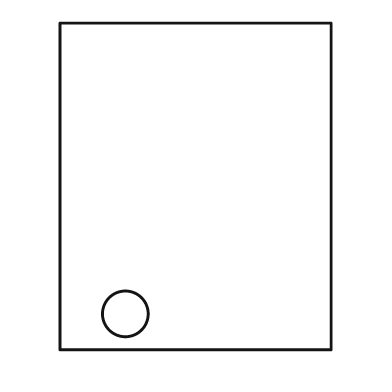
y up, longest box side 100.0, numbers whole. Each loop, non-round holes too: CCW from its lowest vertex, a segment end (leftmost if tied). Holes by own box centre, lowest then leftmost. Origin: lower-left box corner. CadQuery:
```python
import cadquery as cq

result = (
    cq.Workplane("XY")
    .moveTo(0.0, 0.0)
    .lineTo(83.0, 0.0)
    .lineTo(83.0, 100.0)
    .lineTo(0.0, 100.0)
    .close()
    .moveTo(20.0, 11.0)
    .circle(7.0)
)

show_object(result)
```